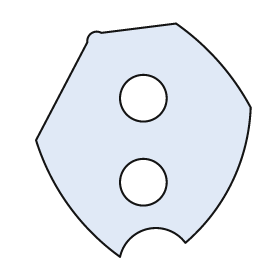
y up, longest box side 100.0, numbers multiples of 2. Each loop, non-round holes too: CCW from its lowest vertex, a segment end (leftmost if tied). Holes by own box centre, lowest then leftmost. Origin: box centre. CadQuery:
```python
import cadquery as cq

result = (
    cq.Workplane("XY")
    .moveTo(-10.0, -50.0)
    .threePointArc((2.0, -38.0), (18.0, -44.0))
    .threePointArc((38.0, -18.0), (46.0, 14.0))
    .threePointArc((32.0, 34.0), (14.0, 50.0))
    .lineTo(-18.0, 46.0)
    .threePointArc((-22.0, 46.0), (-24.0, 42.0))
    .lineTo(-46.0, 0.0)
    .threePointArc((-32.0, -28.0), (-10.0, -50.0))
    .close()
    .moveTo(0.0, -18.0)
    .circle(10.0)
    .moveTo(0.0, 18.0)
    .circle(10.0)
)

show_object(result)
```